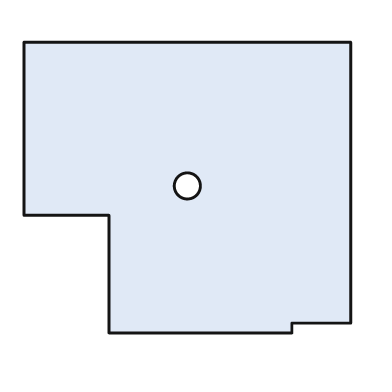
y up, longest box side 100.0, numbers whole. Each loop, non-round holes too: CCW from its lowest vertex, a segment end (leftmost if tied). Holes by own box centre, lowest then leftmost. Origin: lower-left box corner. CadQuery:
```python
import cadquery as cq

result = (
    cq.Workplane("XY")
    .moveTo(26.0, 0.0)
    .lineTo(82.0, 0.0)
    .lineTo(82.0, 3.0)
    .lineTo(100.0, 3.0)
    .lineTo(100.0, 89.0)
    .lineTo(0.0, 89.0)
    .lineTo(0.0, 36.0)
    .lineTo(26.0, 36.0)
    .close()
    .moveTo(50.0, 45.0)
    .circle(4.0)
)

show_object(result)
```